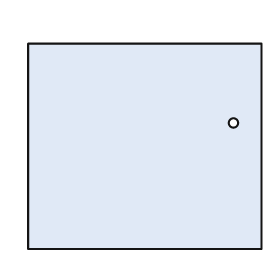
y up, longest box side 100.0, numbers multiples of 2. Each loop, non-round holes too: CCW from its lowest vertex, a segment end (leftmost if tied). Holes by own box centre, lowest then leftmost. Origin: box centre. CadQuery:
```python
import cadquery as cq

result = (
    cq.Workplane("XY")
    .moveTo(-50.0, -44.0)
    .lineTo(50.0, -44.0)
    .lineTo(50.0, 44.0)
    .lineTo(-50.0, 44.0)
    .close()
    .moveTo(38.0, 10.0)
    .circle(2.0)
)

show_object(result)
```